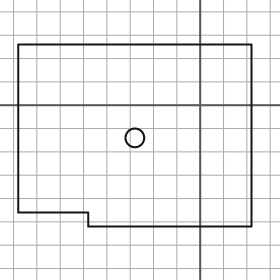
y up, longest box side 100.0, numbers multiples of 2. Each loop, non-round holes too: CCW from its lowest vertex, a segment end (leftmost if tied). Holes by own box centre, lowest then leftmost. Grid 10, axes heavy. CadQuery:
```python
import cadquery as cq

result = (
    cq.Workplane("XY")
    .moveTo(-48.0, -52.0)
    .lineTo(22.0, -52.0)
    .lineTo(22.0, 26.0)
    .lineTo(-78.0, 26.0)
    .lineTo(-78.0, -46.0)
    .lineTo(-48.0, -46.0)
    .close()
    .moveTo(-28.0, -14.0)
    .circle(4.0)
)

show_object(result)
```